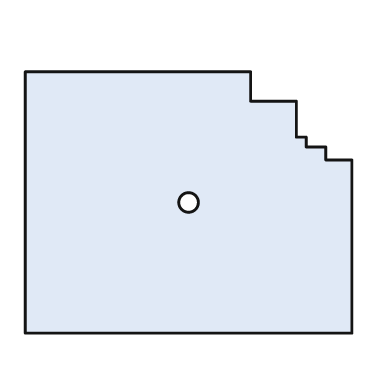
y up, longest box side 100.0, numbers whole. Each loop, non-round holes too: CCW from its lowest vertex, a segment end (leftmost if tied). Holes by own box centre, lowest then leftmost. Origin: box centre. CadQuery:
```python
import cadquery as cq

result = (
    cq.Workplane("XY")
    .moveTo(-50.0, -40.0)
    .lineTo(50.0, -40.0)
    .lineTo(50.0, 13.0)
    .lineTo(42.0, 13.0)
    .lineTo(42.0, 17.0)
    .lineTo(36.0, 17.0)
    .lineTo(36.0, 20.0)
    .lineTo(33.0, 20.0)
    .lineTo(33.0, 31.0)
    .lineTo(19.0, 31.0)
    .lineTo(19.0, 40.0)
    .lineTo(-50.0, 40.0)
    .close()
    .moveTo(0.0, 0.0)
    .circle(3.0)
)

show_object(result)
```